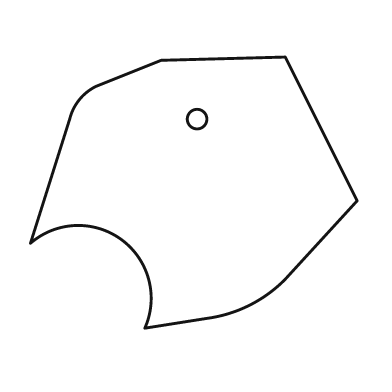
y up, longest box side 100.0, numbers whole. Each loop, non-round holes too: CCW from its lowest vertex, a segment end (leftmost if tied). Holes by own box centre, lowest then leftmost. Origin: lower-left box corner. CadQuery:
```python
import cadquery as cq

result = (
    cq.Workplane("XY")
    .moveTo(35.0, 0.0)
    .lineTo(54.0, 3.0)
    .threePointArc((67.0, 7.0), (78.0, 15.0))
    .lineTo(100.0, 39.0)
    .lineTo(78.0, 83.0)
    .lineTo(40.0, 82.0)
    .lineTo(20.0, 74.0)
    .threePointArc((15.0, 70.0), (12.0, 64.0))
    .lineTo(0.0, 26.0)
    .threePointArc((28.0, 27.0), (35.0, 0.0))
    .close()
    .moveTo(51.0, 64.0)
    .circle(3.0)
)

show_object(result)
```